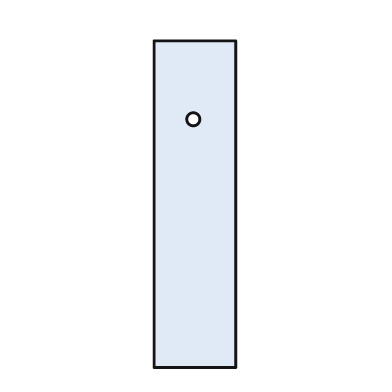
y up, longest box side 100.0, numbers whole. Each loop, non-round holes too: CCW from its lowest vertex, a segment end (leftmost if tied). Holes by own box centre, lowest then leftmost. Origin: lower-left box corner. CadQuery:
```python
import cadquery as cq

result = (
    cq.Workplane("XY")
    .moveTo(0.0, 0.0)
    .lineTo(25.0, 0.0)
    .lineTo(25.0, 100.0)
    .lineTo(0.0, 100.0)
    .close()
    .moveTo(12.0, 76.0)
    .circle(2.0)
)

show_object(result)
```